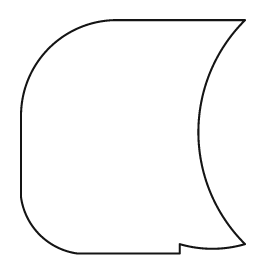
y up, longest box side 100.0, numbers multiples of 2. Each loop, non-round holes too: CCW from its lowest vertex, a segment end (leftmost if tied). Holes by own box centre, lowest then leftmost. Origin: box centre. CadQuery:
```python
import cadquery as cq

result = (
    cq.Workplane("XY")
    .moveTo(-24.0, -50.0)
    .lineTo(20.0, -50.0)
    .lineTo(20.0, -46.0)
    .threePointArc((34.0, -48.0), (48.0, -46.0))
    .threePointArc((28.0, 2.0), (48.0, 50.0))
    .lineTo(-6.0, 50.0)
    .threePointArc((-36.0, 38.0), (-48.0, 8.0))
    .lineTo(-48.0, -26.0)
    .threePointArc((-40.0, -42.0), (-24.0, -50.0))
    .close()
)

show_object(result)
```